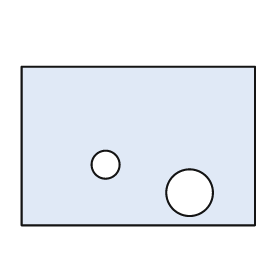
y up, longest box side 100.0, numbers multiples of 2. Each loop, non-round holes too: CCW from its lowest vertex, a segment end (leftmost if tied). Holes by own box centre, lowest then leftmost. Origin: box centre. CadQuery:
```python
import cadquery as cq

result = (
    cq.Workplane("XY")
    .moveTo(-50.0, -34.0)
    .lineTo(50.0, -34.0)
    .lineTo(50.0, 34.0)
    .lineTo(-50.0, 34.0)
    .close()
    .moveTo(22.0, -20.0)
    .circle(10.0)
    .moveTo(-14.0, -8.0)
    .circle(6.0)
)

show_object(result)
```